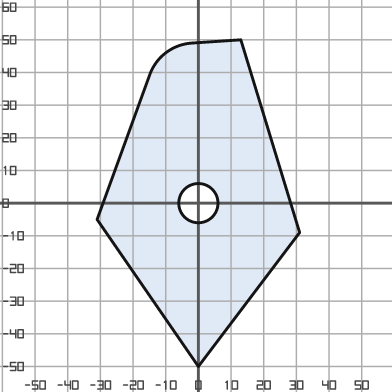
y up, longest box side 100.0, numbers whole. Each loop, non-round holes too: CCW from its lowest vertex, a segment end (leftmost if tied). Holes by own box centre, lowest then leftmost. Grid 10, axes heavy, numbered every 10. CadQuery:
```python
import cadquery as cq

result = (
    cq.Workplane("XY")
    .moveTo(0.0, -50.0)
    .lineTo(31.0, -9.0)
    .lineTo(13.0, 50.0)
    .lineTo(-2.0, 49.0)
    .threePointArc((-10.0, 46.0), (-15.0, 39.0))
    .lineTo(-31.0, -5.0)
    .close()
    .moveTo(0.0, 0.0)
    .circle(6.0)
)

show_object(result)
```